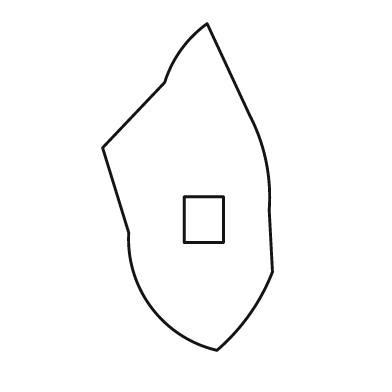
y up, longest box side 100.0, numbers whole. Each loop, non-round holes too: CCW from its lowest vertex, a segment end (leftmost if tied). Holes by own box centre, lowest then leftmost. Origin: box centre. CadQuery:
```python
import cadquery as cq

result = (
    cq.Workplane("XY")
    .moveTo(9.0, -50.0)
    .threePointArc((19.0, -39.0), (26.0, -26.0))
    .lineTo(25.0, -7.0)
    .threePointArc((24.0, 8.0), (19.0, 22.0))
    .lineTo(6.0, 50.0)
    .threePointArc((-2.0, 42.0), (-7.0, 32.0))
    .lineTo(-26.0, 12.0)
    .lineTo(-18.0, -14.0)
    .threePointArc((-11.0, -37.0), (9.0, -50.0))
    .close()
    .moveTo(-1.0, -17.0)
    .lineTo(11.0, -17.0)
    .lineTo(11.0, -3.0)
    .lineTo(-1.0, -3.0)
    .close()
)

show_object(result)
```